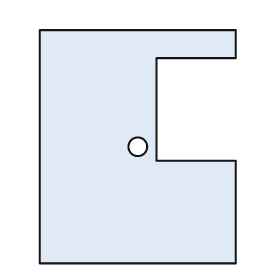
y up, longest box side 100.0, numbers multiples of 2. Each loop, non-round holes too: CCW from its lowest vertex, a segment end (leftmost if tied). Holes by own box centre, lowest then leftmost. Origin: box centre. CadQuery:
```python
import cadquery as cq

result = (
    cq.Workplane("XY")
    .moveTo(-42.0, -50.0)
    .lineTo(42.0, -50.0)
    .lineTo(42.0, -6.0)
    .lineTo(8.0, -6.0)
    .lineTo(8.0, 38.0)
    .lineTo(42.0, 38.0)
    .lineTo(42.0, 50.0)
    .lineTo(-42.0, 50.0)
    .close()
    .moveTo(0.0, 0.0)
    .circle(4.0)
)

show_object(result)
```